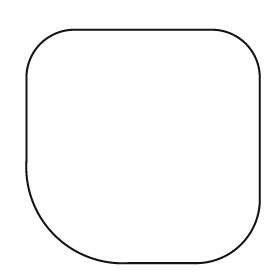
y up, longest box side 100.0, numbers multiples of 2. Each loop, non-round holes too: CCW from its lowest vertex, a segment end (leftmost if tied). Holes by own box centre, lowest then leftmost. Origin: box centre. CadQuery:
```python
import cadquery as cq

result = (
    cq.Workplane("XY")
    .moveTo(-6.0, -50.0)
    .lineTo(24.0, -50.0)
    .threePointArc((42.0, -42.0), (50.0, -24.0))
    .lineTo(50.0, 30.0)
    .threePointArc((44.0, 44.0), (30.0, 50.0))
    .lineTo(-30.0, 50.0)
    .threePointArc((-44.0, 44.0), (-50.0, 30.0))
    .lineTo(-50.0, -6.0)
    .threePointArc((-38.0, -38.0), (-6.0, -50.0))
    .close()
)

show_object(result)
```